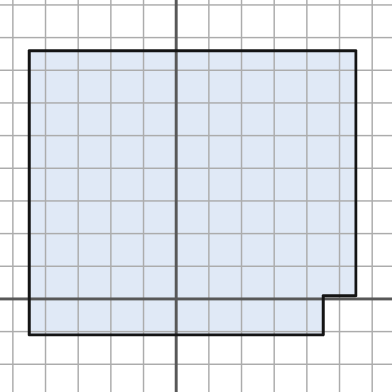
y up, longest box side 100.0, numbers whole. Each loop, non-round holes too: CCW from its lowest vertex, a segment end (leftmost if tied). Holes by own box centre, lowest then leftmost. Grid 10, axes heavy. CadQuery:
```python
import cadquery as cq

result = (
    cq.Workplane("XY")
    .moveTo(-45.0, -11.0)
    .lineTo(45.0, -11.0)
    .lineTo(45.0, 1.0)
    .lineTo(55.0, 1.0)
    .lineTo(55.0, 76.0)
    .lineTo(-45.0, 76.0)
    .close()
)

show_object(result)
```